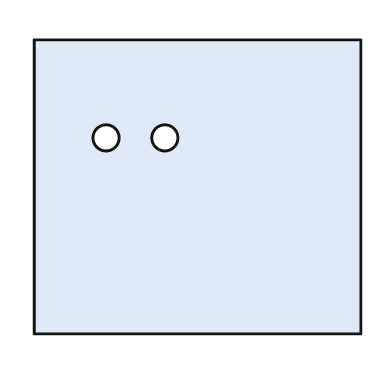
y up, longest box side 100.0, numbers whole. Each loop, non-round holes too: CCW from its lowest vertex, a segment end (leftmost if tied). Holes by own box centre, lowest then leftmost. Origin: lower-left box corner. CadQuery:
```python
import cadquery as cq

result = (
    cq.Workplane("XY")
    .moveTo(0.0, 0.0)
    .lineTo(100.0, 0.0)
    .lineTo(100.0, 90.0)
    .lineTo(0.0, 90.0)
    .close()
    .moveTo(22.0, 60.0)
    .circle(4.0)
    .moveTo(40.0, 60.0)
    .circle(4.0)
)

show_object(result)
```